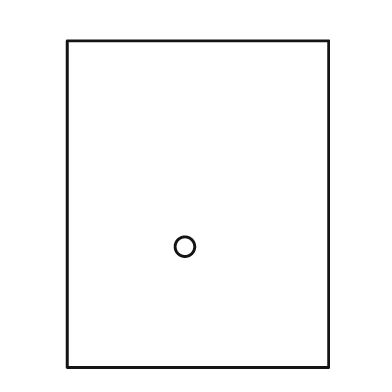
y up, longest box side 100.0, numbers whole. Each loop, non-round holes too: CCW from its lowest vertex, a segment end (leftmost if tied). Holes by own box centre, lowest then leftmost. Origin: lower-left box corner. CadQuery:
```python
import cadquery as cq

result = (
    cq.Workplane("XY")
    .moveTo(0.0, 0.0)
    .lineTo(80.0, 0.0)
    .lineTo(80.0, 100.0)
    .lineTo(0.0, 100.0)
    .close()
    .moveTo(36.0, 37.0)
    .circle(3.0)
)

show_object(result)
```